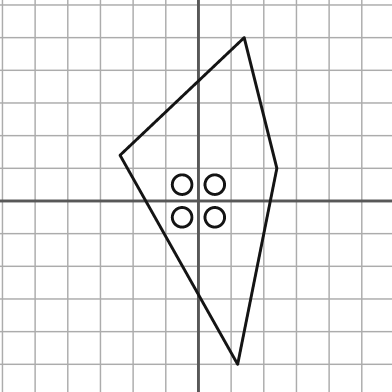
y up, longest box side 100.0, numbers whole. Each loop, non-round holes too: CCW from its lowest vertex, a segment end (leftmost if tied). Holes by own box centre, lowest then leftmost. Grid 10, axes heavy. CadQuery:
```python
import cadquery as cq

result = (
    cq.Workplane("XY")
    .moveTo(12.0, -50.0)
    .lineTo(24.0, 10.0)
    .lineTo(14.0, 50.0)
    .lineTo(-24.0, 14.0)
    .close()
    .moveTo(-5.0, -5.0)
    .circle(3.0)
    .moveTo(5.0, -5.0)
    .circle(3.0)
    .moveTo(-5.0, 5.0)
    .circle(3.0)
    .moveTo(5.0, 5.0)
    .circle(3.0)
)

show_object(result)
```